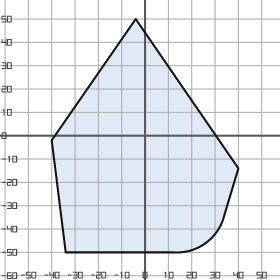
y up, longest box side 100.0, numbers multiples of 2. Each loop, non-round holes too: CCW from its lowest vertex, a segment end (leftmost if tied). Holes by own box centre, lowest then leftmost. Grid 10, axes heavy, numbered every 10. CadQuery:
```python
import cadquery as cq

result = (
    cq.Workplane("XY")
    .moveTo(-34.0, -50.0)
    .lineTo(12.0, -50.0)
    .threePointArc((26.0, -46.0), (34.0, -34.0))
    .lineTo(40.0, -14.0)
    .lineTo(-4.0, 50.0)
    .lineTo(-40.0, -2.0)
    .close()
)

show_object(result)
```